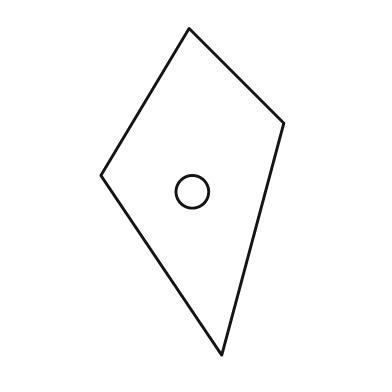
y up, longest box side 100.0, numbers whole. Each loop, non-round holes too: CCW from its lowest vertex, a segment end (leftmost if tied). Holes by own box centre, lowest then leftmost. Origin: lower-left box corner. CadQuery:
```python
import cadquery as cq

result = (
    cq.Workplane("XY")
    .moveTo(37.0, 0.0)
    .lineTo(56.0, 71.0)
    .lineTo(27.0, 100.0)
    .lineTo(0.0, 55.0)
    .close()
    .moveTo(28.0, 50.0)
    .circle(5.0)
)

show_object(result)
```